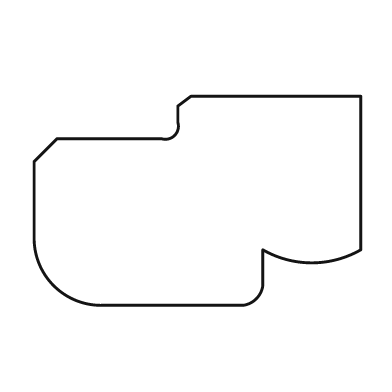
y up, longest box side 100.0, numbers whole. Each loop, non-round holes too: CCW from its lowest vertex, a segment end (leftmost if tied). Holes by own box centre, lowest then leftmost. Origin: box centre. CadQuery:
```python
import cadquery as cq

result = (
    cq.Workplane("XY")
    .moveTo(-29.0, -32.0)
    .lineTo(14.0, -32.0)
    .threePointArc((18.0, -30.0), (20.0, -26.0))
    .lineTo(20.0, -15.0)
    .threePointArc((35.0, -19.0), (50.0, -15.0))
    .lineTo(50.0, 32.0)
    .lineTo(-2.0, 32.0)
    .lineTo(-6.0, 29.0)
    .lineTo(-6.0, 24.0)
    .threePointArc((-7.0, 20.0), (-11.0, 19.0))
    .lineTo(-43.0, 19.0)
    .lineTo(-50.0, 12.0)
    .lineTo(-50.0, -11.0)
    .threePointArc((-44.0, -26.0), (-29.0, -32.0))
    .close()
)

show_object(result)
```